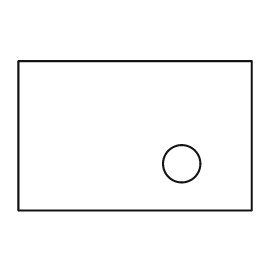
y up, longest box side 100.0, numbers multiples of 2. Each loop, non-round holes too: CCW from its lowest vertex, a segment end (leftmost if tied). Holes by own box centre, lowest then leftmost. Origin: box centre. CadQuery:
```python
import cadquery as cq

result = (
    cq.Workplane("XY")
    .moveTo(-50.0, -32.0)
    .lineTo(50.0, -32.0)
    .lineTo(50.0, 32.0)
    .lineTo(-50.0, 32.0)
    .close()
    .moveTo(20.0, -12.0)
    .circle(8.0)
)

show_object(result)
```